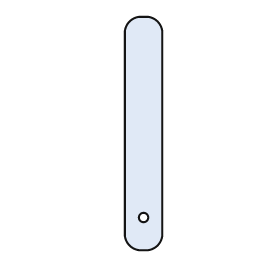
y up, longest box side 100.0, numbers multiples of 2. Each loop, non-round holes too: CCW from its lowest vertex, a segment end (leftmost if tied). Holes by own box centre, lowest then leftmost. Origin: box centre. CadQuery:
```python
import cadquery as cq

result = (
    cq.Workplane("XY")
    .moveTo(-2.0, -50.0)
    .lineTo(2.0, -50.0)
    .threePointArc((6.0, -48.0), (8.0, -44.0))
    .lineTo(8.0, 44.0)
    .threePointArc((6.0, 48.0), (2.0, 50.0))
    .lineTo(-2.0, 50.0)
    .threePointArc((-6.0, 48.0), (-8.0, 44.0))
    .lineTo(-8.0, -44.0)
    .threePointArc((-6.0, -48.0), (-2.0, -50.0))
    .close()
    .moveTo(0.0, -36.0)
    .circle(2.0)
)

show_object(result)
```